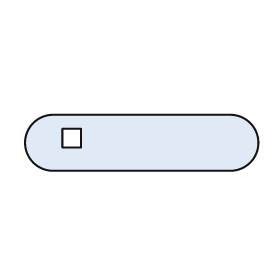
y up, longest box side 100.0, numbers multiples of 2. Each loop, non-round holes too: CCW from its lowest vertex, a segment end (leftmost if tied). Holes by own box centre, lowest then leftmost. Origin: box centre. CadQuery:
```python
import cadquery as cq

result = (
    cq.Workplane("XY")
    .moveTo(-38.0, -12.0)
    .lineTo(38.0, -12.0)
    .threePointArc((50.0, 0.0), (38.0, 12.0))
    .lineTo(-38.0, 12.0)
    .threePointArc((-50.0, 0.0), (-38.0, -12.0))
    .close()
    .moveTo(-34.0, -2.0)
    .lineTo(-26.0, -2.0)
    .lineTo(-26.0, 6.0)
    .lineTo(-34.0, 6.0)
    .close()
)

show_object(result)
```